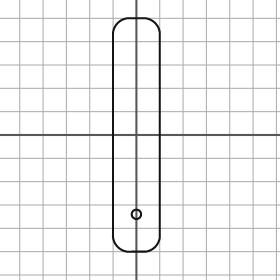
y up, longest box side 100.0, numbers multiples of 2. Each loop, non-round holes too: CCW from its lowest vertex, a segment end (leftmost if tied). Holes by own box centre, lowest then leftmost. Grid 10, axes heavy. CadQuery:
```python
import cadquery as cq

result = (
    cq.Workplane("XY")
    .moveTo(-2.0, -50.0)
    .lineTo(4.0, -50.0)
    .threePointArc((8.0, -48.0), (10.0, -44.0))
    .lineTo(10.0, 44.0)
    .threePointArc((8.0, 48.0), (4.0, 50.0))
    .lineTo(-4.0, 50.0)
    .threePointArc((-8.0, 48.0), (-10.0, 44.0))
    .lineTo(-10.0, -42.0)
    .threePointArc((-8.0, -48.0), (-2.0, -50.0))
    .close()
    .moveTo(0.0, -34.0)
    .circle(2.0)
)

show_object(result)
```